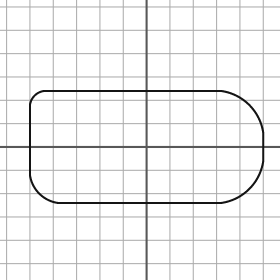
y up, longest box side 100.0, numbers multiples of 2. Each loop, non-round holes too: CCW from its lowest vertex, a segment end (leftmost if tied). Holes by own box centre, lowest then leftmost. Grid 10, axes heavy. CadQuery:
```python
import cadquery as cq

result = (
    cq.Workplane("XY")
    .moveTo(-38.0, -24.0)
    .lineTo(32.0, -24.0)
    .threePointArc((44.0, -18.0), (50.0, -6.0))
    .lineTo(50.0, 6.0)
    .threePointArc((44.0, 18.0), (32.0, 24.0))
    .lineTo(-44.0, 24.0)
    .threePointArc((-48.0, 22.0), (-50.0, 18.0))
    .lineTo(-50.0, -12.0)
    .threePointArc((-46.0, -20.0), (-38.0, -24.0))
    .close()
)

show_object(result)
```